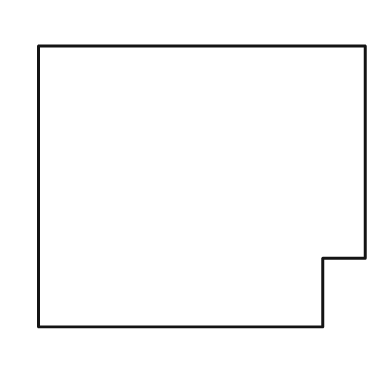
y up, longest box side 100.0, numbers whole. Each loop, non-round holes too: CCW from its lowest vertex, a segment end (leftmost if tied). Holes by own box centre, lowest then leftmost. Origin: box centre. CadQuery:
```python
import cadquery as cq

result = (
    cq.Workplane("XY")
    .moveTo(-50.0, -43.0)
    .lineTo(37.0, -43.0)
    .lineTo(37.0, -22.0)
    .lineTo(50.0, -22.0)
    .lineTo(50.0, 43.0)
    .lineTo(-50.0, 43.0)
    .close()
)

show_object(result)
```